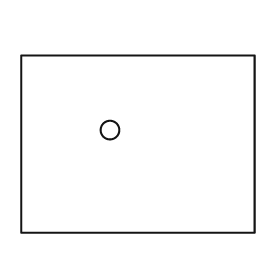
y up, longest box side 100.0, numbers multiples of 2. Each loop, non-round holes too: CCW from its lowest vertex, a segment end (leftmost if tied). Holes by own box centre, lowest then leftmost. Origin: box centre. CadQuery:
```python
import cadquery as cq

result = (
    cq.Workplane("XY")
    .moveTo(-50.0, -38.0)
    .lineTo(50.0, -38.0)
    .lineTo(50.0, 38.0)
    .lineTo(-50.0, 38.0)
    .close()
    .moveTo(-12.0, 6.0)
    .circle(4.0)
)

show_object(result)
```